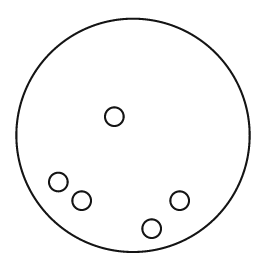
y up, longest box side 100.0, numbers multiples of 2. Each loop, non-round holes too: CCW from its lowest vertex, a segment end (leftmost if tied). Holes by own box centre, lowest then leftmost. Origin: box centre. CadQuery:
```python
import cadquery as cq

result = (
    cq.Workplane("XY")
    .moveTo(0.0, 0.0)
    .circle(50.0)
    .moveTo(8.0, -40.0)
    .circle(4.0)
    .moveTo(-22.0, -28.0)
    .circle(4.0)
    .moveTo(20.0, -28.0)
    .circle(4.0)
    .moveTo(-32.0, -20.0)
    .circle(4.0)
    .moveTo(-8.0, 8.0)
    .circle(4.0)
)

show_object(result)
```